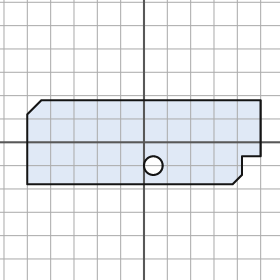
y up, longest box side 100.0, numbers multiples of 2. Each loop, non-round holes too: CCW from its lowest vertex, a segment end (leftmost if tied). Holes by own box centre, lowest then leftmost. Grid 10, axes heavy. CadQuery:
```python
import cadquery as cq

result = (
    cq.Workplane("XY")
    .moveTo(-50.0, -18.0)
    .lineTo(38.0, -18.0)
    .lineTo(42.0, -14.0)
    .lineTo(42.0, -6.0)
    .lineTo(50.0, -6.0)
    .lineTo(50.0, 18.0)
    .lineTo(-44.0, 18.0)
    .lineTo(-50.0, 12.0)
    .close()
    .moveTo(4.0, -10.0)
    .circle(4.0)
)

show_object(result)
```